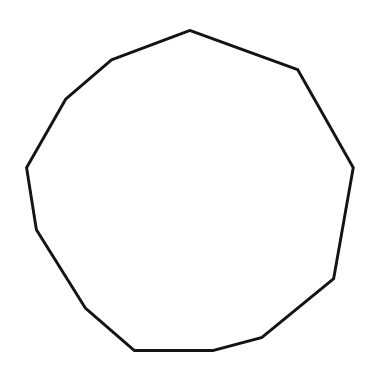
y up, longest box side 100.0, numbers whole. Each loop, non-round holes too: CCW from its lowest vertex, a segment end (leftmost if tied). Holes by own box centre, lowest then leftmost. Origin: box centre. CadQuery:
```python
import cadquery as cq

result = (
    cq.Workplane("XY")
    .moveTo(-17.0, -49.0)
    .lineTo(7.0, -49.0)
    .lineTo(22.0, -45.0)
    .lineTo(44.0, -27.0)
    .lineTo(50.0, 7.0)
    .lineTo(33.0, 37.0)
    .lineTo(0.0, 49.0)
    .lineTo(-24.0, 40.0)
    .lineTo(-38.0, 28.0)
    .lineTo(-50.0, 7.0)
    .lineTo(-47.0, -12.0)
    .lineTo(-32.0, -36.0)
    .close()
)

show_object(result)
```